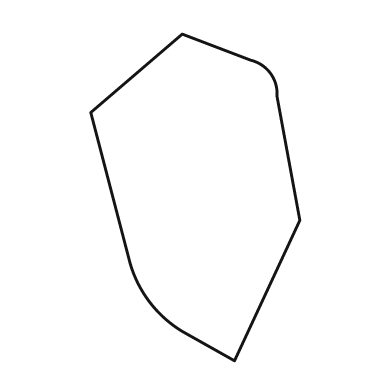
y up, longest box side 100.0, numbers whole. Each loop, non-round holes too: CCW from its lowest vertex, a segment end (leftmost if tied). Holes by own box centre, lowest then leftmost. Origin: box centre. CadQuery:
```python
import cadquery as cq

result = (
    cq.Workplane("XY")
    .moveTo(12.0, -50.0)
    .lineTo(32.0, -7.0)
    .lineTo(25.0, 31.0)
    .threePointArc((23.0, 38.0), (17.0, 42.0))
    .lineTo(-4.0, 50.0)
    .lineTo(-32.0, 26.0)
    .lineTo(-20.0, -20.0)
    .threePointArc((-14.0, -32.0), (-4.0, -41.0))
    .close()
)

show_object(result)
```